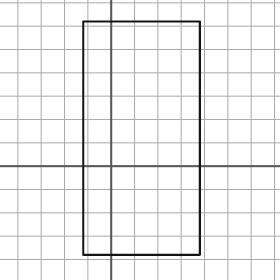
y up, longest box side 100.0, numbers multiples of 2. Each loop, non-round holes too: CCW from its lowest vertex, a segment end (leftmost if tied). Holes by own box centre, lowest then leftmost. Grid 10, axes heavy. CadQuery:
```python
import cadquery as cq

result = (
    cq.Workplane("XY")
    .moveTo(-12.0, -38.0)
    .lineTo(38.0, -38.0)
    .lineTo(38.0, 62.0)
    .lineTo(-12.0, 62.0)
    .close()
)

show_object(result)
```